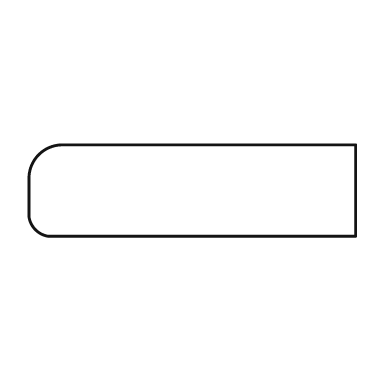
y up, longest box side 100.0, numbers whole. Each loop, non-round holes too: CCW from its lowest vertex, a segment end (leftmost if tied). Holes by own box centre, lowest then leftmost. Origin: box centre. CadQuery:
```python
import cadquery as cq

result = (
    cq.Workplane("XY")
    .moveTo(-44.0, -14.0)
    .lineTo(50.0, -14.0)
    .lineTo(50.0, 14.0)
    .lineTo(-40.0, 14.0)
    .threePointArc((-47.0, 11.0), (-50.0, 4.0))
    .lineTo(-50.0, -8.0)
    .threePointArc((-48.0, -12.0), (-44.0, -14.0))
    .close()
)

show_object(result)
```